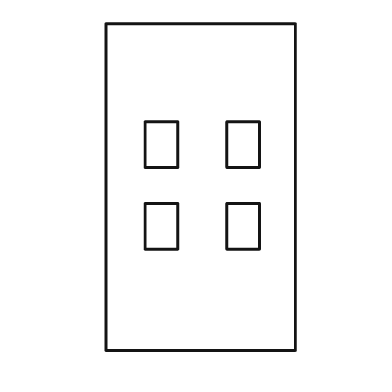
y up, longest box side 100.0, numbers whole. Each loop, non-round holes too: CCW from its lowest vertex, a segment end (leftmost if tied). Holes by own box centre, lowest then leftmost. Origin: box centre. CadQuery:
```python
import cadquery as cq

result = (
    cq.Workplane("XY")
    .moveTo(-29.0, -50.0)
    .lineTo(29.0, -50.0)
    .lineTo(29.0, 50.0)
    .lineTo(-29.0, 50.0)
    .close()
    .moveTo(-17.0, -19.0)
    .lineTo(-7.0, -19.0)
    .lineTo(-7.0, -5.0)
    .lineTo(-17.0, -5.0)
    .close()
    .moveTo(8.0, -19.0)
    .lineTo(18.0, -19.0)
    .lineTo(18.0, -5.0)
    .lineTo(8.0, -5.0)
    .close()
    .moveTo(-17.0, 6.0)
    .lineTo(-7.0, 6.0)
    .lineTo(-7.0, 20.0)
    .lineTo(-17.0, 20.0)
    .close()
    .moveTo(8.0, 6.0)
    .lineTo(18.0, 6.0)
    .lineTo(18.0, 20.0)
    .lineTo(8.0, 20.0)
    .close()
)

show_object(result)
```